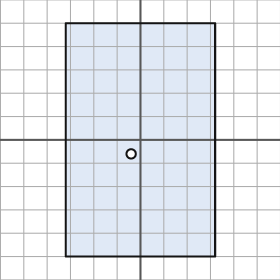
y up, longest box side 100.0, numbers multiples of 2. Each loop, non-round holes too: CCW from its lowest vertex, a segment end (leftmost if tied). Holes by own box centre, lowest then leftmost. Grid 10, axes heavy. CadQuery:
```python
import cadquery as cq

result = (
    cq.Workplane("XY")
    .moveTo(-32.0, -50.0)
    .lineTo(32.0, -50.0)
    .lineTo(32.0, 50.0)
    .lineTo(-32.0, 50.0)
    .close()
    .moveTo(-4.0, -6.0)
    .circle(2.0)
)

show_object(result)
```